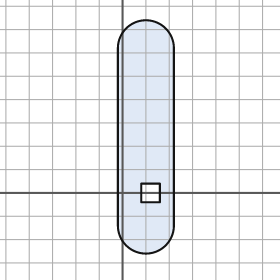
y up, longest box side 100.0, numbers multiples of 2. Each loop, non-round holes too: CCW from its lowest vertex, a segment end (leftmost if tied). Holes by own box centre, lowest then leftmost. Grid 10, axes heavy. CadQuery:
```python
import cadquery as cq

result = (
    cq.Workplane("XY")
    .moveTo(-2.0, -14.0)
    .threePointArc((10.0, -26.0), (22.0, -14.0))
    .lineTo(22.0, 62.0)
    .threePointArc((10.0, 74.0), (-2.0, 62.0))
    .close()
    .moveTo(8.0, -4.0)
    .lineTo(16.0, -4.0)
    .lineTo(16.0, 4.0)
    .lineTo(8.0, 4.0)
    .close()
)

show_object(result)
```